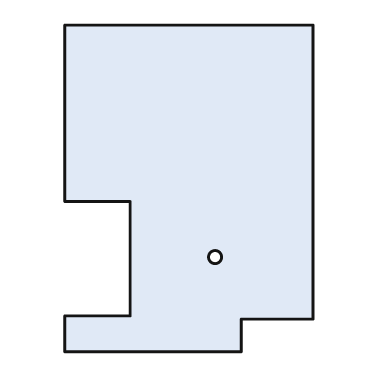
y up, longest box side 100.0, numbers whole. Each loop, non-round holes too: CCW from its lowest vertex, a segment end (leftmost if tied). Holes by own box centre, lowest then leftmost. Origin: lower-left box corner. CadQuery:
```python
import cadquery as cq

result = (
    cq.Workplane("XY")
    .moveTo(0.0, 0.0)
    .lineTo(54.0, 0.0)
    .lineTo(54.0, 10.0)
    .lineTo(76.0, 10.0)
    .lineTo(76.0, 100.0)
    .lineTo(0.0, 100.0)
    .lineTo(0.0, 46.0)
    .lineTo(20.0, 46.0)
    .lineTo(20.0, 11.0)
    .lineTo(0.0, 11.0)
    .close()
    .moveTo(46.0, 29.0)
    .circle(2.0)
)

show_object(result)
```